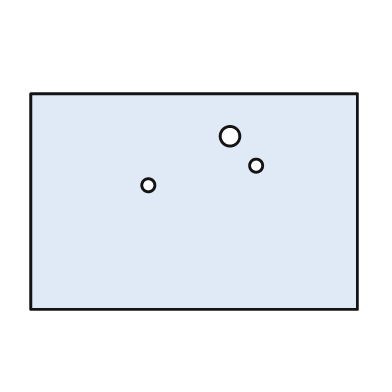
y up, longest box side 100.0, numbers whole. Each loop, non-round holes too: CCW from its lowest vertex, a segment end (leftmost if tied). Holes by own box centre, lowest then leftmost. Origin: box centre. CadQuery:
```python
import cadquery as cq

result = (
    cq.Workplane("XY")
    .moveTo(-50.0, -33.0)
    .lineTo(50.0, -33.0)
    .lineTo(50.0, 33.0)
    .lineTo(-50.0, 33.0)
    .close()
    .moveTo(-14.0, 5.0)
    .circle(2.0)
    .moveTo(19.0, 11.0)
    .circle(2.0)
    .moveTo(11.0, 20.0)
    .circle(3.0)
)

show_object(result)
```